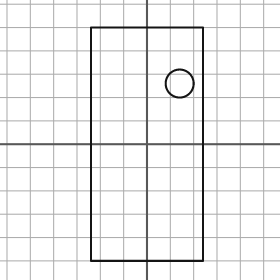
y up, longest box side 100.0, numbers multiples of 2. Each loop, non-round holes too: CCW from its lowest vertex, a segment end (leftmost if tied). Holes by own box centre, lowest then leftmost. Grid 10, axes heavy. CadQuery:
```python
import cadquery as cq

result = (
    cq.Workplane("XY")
    .moveTo(-24.0, -50.0)
    .lineTo(24.0, -50.0)
    .lineTo(24.0, 50.0)
    .lineTo(-24.0, 50.0)
    .close()
    .moveTo(14.0, 26.0)
    .circle(6.0)
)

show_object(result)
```